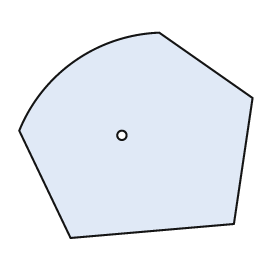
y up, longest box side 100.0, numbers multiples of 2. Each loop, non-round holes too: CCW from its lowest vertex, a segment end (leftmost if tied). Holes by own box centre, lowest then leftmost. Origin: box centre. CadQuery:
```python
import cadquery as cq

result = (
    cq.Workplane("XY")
    .moveTo(-28.0, -44.0)
    .lineTo(42.0, -38.0)
    .lineTo(50.0, 16.0)
    .lineTo(10.0, 44.0)
    .threePointArc((-26.0, 32.0), (-50.0, 2.0))
    .close()
    .moveTo(-6.0, 0.0)
    .circle(2.0)
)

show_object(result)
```